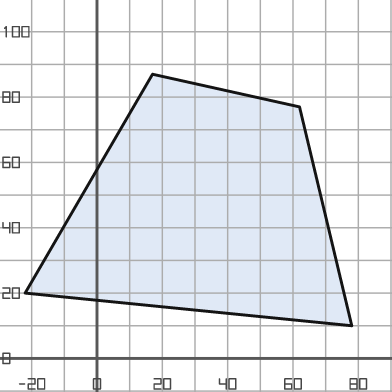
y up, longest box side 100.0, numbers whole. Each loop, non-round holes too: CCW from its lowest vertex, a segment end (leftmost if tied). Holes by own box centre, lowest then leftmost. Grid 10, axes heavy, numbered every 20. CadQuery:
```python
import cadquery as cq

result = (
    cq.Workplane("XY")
    .moveTo(78.0, 10.0)
    .lineTo(62.0, 77.0)
    .lineTo(17.0, 87.0)
    .lineTo(-22.0, 20.0)
    .close()
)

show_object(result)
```